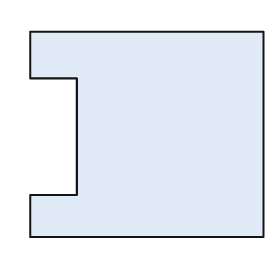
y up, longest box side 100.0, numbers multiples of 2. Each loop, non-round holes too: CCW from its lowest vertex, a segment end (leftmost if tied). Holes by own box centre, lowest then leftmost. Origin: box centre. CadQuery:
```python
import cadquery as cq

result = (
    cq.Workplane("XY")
    .moveTo(-50.0, -44.0)
    .lineTo(50.0, -44.0)
    .lineTo(50.0, 44.0)
    .lineTo(-50.0, 44.0)
    .lineTo(-50.0, 24.0)
    .lineTo(-30.0, 24.0)
    .lineTo(-30.0, -26.0)
    .lineTo(-50.0, -26.0)
    .close()
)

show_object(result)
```